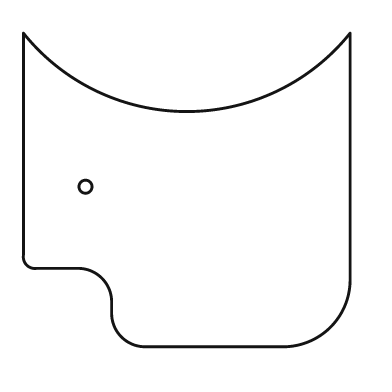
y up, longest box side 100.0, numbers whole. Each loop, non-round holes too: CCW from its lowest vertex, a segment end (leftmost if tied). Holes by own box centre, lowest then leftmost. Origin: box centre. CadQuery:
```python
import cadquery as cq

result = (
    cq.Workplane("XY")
    .moveTo(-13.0, -48.0)
    .lineTo(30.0, -48.0)
    .threePointArc((44.0, -42.0), (50.0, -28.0))
    .lineTo(50.0, 48.0)
    .threePointArc((0.0, 24.0), (-50.0, 48.0))
    .lineTo(-50.0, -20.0)
    .threePointArc((-49.0, -23.0), (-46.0, -24.0))
    .lineTo(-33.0, -24.0)
    .threePointArc((-26.0, -27.0), (-23.0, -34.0))
    .lineTo(-23.0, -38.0)
    .threePointArc((-20.0, -45.0), (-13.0, -48.0))
    .close()
    .moveTo(-31.0, 1.0)
    .circle(2.0)
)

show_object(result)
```